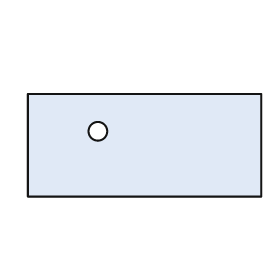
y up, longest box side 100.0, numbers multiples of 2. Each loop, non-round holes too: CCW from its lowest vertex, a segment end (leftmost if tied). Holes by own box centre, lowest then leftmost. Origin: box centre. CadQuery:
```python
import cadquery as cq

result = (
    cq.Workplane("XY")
    .moveTo(-50.0, -22.0)
    .lineTo(50.0, -22.0)
    .lineTo(50.0, 22.0)
    .lineTo(-50.0, 22.0)
    .close()
    .moveTo(-20.0, 6.0)
    .circle(4.0)
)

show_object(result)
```